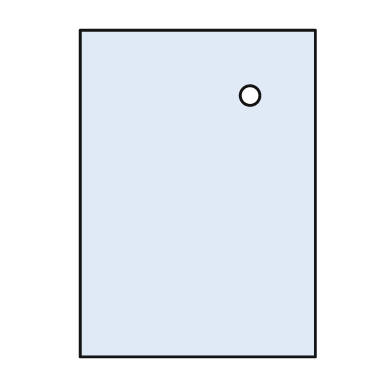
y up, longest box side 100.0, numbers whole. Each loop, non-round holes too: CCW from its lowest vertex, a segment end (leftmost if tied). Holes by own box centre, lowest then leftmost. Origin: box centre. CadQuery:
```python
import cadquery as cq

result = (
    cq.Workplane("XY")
    .moveTo(-36.0, -50.0)
    .lineTo(36.0, -50.0)
    .lineTo(36.0, 50.0)
    .lineTo(-36.0, 50.0)
    .close()
    .moveTo(16.0, 30.0)
    .circle(3.0)
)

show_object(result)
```